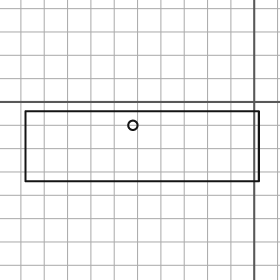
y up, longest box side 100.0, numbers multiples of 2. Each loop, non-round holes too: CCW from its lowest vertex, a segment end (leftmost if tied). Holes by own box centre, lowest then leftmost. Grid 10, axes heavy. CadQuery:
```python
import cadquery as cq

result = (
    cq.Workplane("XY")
    .moveTo(-98.0, -34.0)
    .lineTo(2.0, -34.0)
    .lineTo(2.0, -4.0)
    .lineTo(-98.0, -4.0)
    .close()
    .moveTo(-52.0, -10.0)
    .circle(2.0)
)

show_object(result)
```